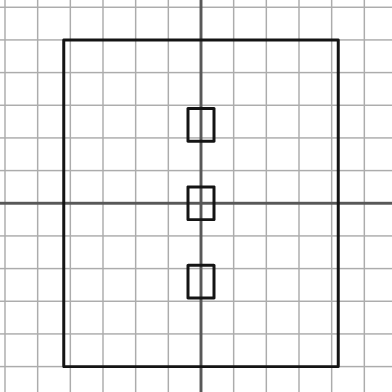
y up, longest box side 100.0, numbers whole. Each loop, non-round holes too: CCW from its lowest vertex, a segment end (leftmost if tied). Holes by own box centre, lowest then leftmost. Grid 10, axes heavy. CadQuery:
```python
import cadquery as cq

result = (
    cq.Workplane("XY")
    .moveTo(-42.0, -50.0)
    .lineTo(42.0, -50.0)
    .lineTo(42.0, 50.0)
    .lineTo(-42.0, 50.0)
    .close()
    .moveTo(-4.0, -29.0)
    .lineTo(4.0, -29.0)
    .lineTo(4.0, -19.0)
    .lineTo(-4.0, -19.0)
    .close()
    .moveTo(-4.0, -5.0)
    .lineTo(4.0, -5.0)
    .lineTo(4.0, 5.0)
    .lineTo(-4.0, 5.0)
    .close()
    .moveTo(-4.0, 19.0)
    .lineTo(4.0, 19.0)
    .lineTo(4.0, 29.0)
    .lineTo(-4.0, 29.0)
    .close()
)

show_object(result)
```